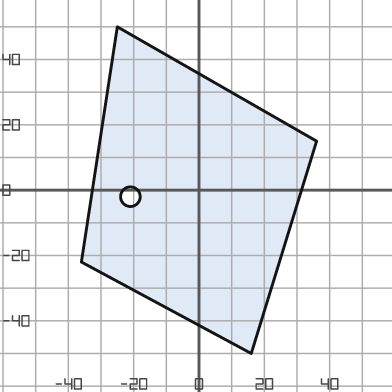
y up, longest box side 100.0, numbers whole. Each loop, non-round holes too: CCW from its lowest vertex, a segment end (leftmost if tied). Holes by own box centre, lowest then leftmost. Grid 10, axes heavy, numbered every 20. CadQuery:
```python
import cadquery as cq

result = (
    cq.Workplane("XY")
    .moveTo(16.0, -50.0)
    .lineTo(36.0, 15.0)
    .lineTo(-25.0, 50.0)
    .lineTo(-36.0, -22.0)
    .close()
    .moveTo(-21.0, -2.0)
    .circle(3.0)
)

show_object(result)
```